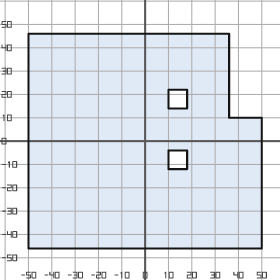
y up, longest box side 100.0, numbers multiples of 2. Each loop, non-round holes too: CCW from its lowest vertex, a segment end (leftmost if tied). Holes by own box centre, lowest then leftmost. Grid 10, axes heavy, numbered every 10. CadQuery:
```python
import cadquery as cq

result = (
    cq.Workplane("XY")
    .moveTo(-50.0, -46.0)
    .lineTo(50.0, -46.0)
    .lineTo(50.0, 10.0)
    .lineTo(36.0, 10.0)
    .lineTo(36.0, 46.0)
    .lineTo(-50.0, 46.0)
    .close()
    .moveTo(10.0, -12.0)
    .lineTo(18.0, -12.0)
    .lineTo(18.0, -4.0)
    .lineTo(10.0, -4.0)
    .close()
    .moveTo(10.0, 14.0)
    .lineTo(18.0, 14.0)
    .lineTo(18.0, 22.0)
    .lineTo(10.0, 22.0)
    .close()
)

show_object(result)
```